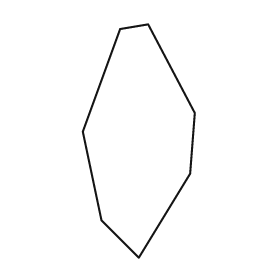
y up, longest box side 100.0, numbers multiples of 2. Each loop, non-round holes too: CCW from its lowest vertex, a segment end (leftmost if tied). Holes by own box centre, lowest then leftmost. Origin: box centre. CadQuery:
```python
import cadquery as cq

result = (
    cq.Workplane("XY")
    .moveTo(0.0, -50.0)
    .lineTo(22.0, -14.0)
    .lineTo(24.0, 12.0)
    .lineTo(4.0, 50.0)
    .lineTo(-8.0, 48.0)
    .lineTo(-24.0, 4.0)
    .lineTo(-16.0, -34.0)
    .close()
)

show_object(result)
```